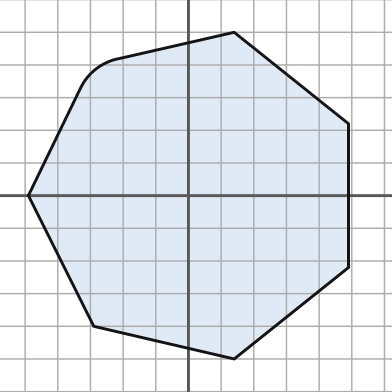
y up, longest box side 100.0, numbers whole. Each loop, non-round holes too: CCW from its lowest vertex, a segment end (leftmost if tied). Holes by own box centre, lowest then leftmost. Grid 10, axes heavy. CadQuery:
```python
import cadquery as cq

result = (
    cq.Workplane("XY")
    .moveTo(14.0, -50.0)
    .lineTo(49.0, -22.0)
    .lineTo(49.0, 22.0)
    .lineTo(14.0, 50.0)
    .lineTo(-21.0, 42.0)
    .threePointArc((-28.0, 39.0), (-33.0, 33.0))
    .lineTo(-49.0, 0.0)
    .lineTo(-29.0, -40.0)
    .close()
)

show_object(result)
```